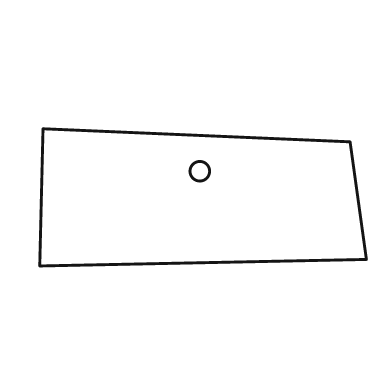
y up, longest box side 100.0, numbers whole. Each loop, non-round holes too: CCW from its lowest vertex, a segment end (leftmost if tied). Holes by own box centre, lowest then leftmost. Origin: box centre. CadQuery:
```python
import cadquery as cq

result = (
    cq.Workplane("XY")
    .moveTo(-50.0, -21.0)
    .lineTo(50.0, -19.0)
    .lineTo(45.0, 17.0)
    .lineTo(-49.0, 21.0)
    .close()
    .moveTo(-1.0, 8.0)
    .circle(3.0)
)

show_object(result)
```